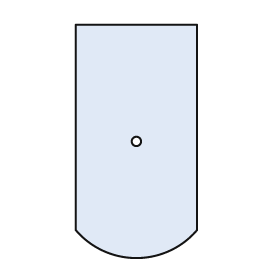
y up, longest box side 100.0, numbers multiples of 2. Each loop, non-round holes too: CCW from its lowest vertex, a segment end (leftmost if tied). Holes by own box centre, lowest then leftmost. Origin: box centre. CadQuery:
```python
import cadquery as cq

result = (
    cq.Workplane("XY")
    .moveTo(-26.0, -38.0)
    .threePointArc((0.0, -50.0), (26.0, -38.0))
    .lineTo(26.0, 50.0)
    .lineTo(-26.0, 50.0)
    .close()
    .moveTo(0.0, 0.0)
    .circle(2.0)
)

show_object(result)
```